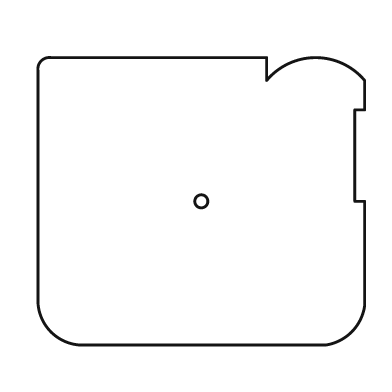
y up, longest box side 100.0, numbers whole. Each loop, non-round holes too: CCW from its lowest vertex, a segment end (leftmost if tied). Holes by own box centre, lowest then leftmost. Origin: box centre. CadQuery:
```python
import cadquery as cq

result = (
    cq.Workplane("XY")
    .moveTo(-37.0, -44.0)
    .lineTo(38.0, -44.0)
    .threePointArc((46.0, -40.0), (50.0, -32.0))
    .lineTo(50.0, 0.0)
    .lineTo(47.0, 0.0)
    .lineTo(47.0, 28.0)
    .lineTo(50.0, 28.0)
    .lineTo(50.0, 37.0)
    .threePointArc((35.0, 44.0), (20.0, 37.0))
    .lineTo(20.0, 44.0)
    .lineTo(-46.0, 44.0)
    .threePointArc((-49.0, 43.0), (-50.0, 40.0))
    .lineTo(-50.0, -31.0)
    .threePointArc((-46.0, -40.0), (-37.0, -44.0))
    .close()
    .moveTo(0.0, 0.0)
    .circle(2.0)
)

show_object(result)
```